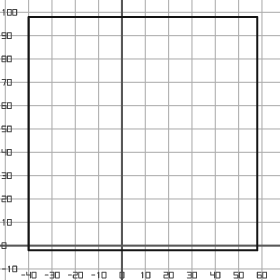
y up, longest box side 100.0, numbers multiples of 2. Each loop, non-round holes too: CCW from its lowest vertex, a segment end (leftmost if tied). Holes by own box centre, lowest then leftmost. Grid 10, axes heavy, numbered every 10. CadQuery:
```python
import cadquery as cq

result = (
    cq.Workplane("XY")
    .moveTo(-40.0, -2.0)
    .lineTo(58.0, -2.0)
    .lineTo(58.0, 98.0)
    .lineTo(-40.0, 98.0)
    .close()
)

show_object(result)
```